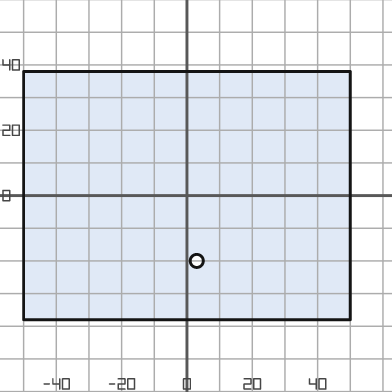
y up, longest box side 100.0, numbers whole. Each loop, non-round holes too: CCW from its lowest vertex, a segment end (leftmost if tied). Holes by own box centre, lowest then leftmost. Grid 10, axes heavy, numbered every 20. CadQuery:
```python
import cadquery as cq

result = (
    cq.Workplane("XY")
    .moveTo(-50.0, -38.0)
    .lineTo(50.0, -38.0)
    .lineTo(50.0, 38.0)
    .lineTo(-50.0, 38.0)
    .close()
    .moveTo(3.0, -20.0)
    .circle(2.0)
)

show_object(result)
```